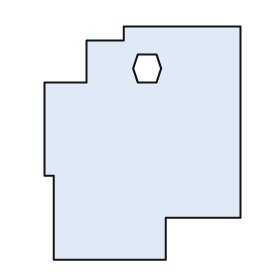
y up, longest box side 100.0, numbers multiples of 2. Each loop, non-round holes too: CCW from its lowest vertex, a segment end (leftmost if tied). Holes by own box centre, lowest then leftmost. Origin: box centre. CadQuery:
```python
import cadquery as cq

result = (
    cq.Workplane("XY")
    .moveTo(-38.0, -50.0)
    .lineTo(10.0, -50.0)
    .lineTo(10.0, -32.0)
    .lineTo(42.0, -32.0)
    .lineTo(42.0, 50.0)
    .lineTo(-8.0, 50.0)
    .lineTo(-8.0, 44.0)
    .lineTo(-24.0, 44.0)
    .lineTo(-24.0, 26.0)
    .lineTo(-42.0, 26.0)
    .lineTo(-42.0, -14.0)
    .lineTo(-38.0, -14.0)
    .close()
    .moveTo(-2.0, 26.0)
    .lineTo(6.0, 26.0)
    .lineTo(8.0, 32.0)
    .lineTo(6.0, 38.0)
    .lineTo(-2.0, 38.0)
    .lineTo(-4.0, 32.0)
    .close()
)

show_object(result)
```